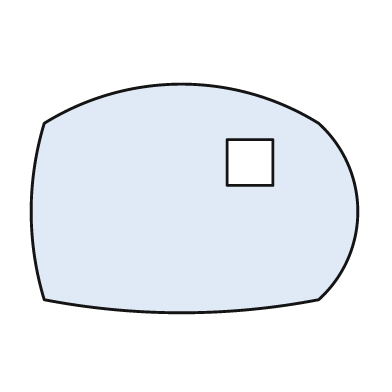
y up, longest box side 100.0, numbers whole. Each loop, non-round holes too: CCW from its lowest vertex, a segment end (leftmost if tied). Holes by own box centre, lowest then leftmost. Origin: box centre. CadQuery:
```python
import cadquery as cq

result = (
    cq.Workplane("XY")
    .moveTo(-46.0, -31.0)
    .threePointArc((-4.0, -35.0), (38.0, -31.0))
    .threePointArc((50.0, -4.0), (38.0, 23.0))
    .threePointArc((-4.0, 35.0), (-46.0, 23.0))
    .threePointArc((-50.0, -4.0), (-46.0, -31.0))
    .close()
    .moveTo(10.0, 4.0)
    .lineTo(24.0, 4.0)
    .lineTo(24.0, 18.0)
    .lineTo(10.0, 18.0)
    .close()
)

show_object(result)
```